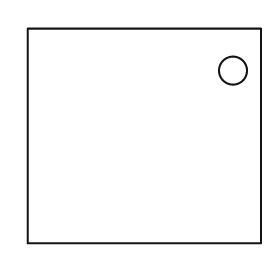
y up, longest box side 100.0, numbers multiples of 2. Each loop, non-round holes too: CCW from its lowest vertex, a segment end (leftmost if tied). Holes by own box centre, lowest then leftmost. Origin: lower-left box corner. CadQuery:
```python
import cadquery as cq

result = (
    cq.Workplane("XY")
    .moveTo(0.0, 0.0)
    .lineTo(100.0, 0.0)
    .lineTo(100.0, 92.0)
    .lineTo(0.0, 92.0)
    .close()
    .moveTo(88.0, 74.0)
    .circle(6.0)
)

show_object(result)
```